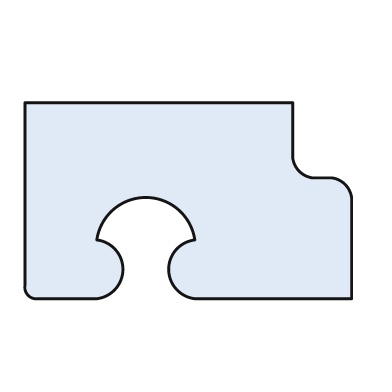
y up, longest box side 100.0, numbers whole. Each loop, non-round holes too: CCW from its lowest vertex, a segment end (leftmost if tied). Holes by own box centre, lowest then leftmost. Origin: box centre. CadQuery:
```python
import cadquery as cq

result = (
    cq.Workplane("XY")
    .moveTo(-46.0, -30.0)
    .lineTo(-28.0, -30.0)
    .threePointArc((-20.0, -21.0), (-28.0, -12.0))
    .threePointArc((-13.0, 1.0), (2.0, -12.0))
    .threePointArc((-6.0, -21.0), (2.0, -30.0))
    .lineTo(50.0, -30.0)
    .lineTo(50.0, 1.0)
    .threePointArc((48.0, 5.0), (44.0, 7.0))
    .lineTo(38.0, 7.0)
    .threePointArc((34.0, 9.0), (32.0, 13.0))
    .lineTo(32.0, 30.0)
    .lineTo(-50.0, 30.0)
    .lineTo(-50.0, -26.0)
    .threePointArc((-49.0, -29.0), (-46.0, -30.0))
    .close()
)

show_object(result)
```